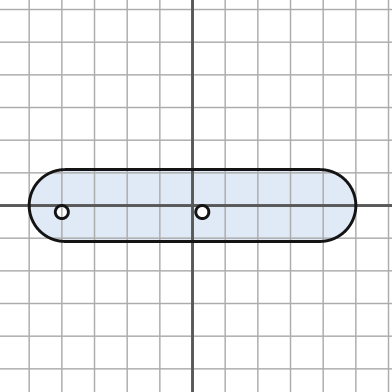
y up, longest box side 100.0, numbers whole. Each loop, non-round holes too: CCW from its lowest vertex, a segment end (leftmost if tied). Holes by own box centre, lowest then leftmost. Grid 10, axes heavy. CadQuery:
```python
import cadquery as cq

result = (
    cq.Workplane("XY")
    .moveTo(-39.0, -11.0)
    .lineTo(39.0, -11.0)
    .threePointArc((50.0, 0.0), (39.0, 11.0))
    .lineTo(-39.0, 11.0)
    .threePointArc((-50.0, 0.0), (-39.0, -11.0))
    .close()
    .moveTo(-40.0, -2.0)
    .circle(2.0)
    .moveTo(3.0, -2.0)
    .circle(2.0)
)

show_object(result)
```